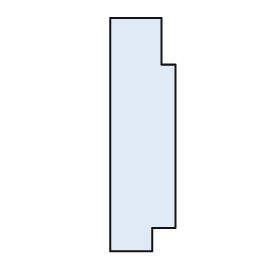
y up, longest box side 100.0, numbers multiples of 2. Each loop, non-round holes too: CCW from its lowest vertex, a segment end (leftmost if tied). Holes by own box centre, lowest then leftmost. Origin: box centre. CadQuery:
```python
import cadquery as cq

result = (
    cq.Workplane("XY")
    .moveTo(-14.0, -50.0)
    .lineTo(4.0, -50.0)
    .lineTo(4.0, -40.0)
    .lineTo(14.0, -40.0)
    .lineTo(14.0, 30.0)
    .lineTo(8.0, 30.0)
    .lineTo(8.0, 50.0)
    .lineTo(-14.0, 50.0)
    .close()
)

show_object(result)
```